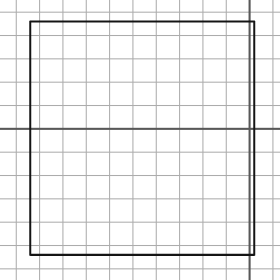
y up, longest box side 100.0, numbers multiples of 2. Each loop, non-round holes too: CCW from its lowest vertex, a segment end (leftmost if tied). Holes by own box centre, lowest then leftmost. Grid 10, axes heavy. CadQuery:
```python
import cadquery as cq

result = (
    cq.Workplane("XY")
    .moveTo(-94.0, -54.0)
    .lineTo(2.0, -54.0)
    .lineTo(2.0, 46.0)
    .lineTo(-94.0, 46.0)
    .close()
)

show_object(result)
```